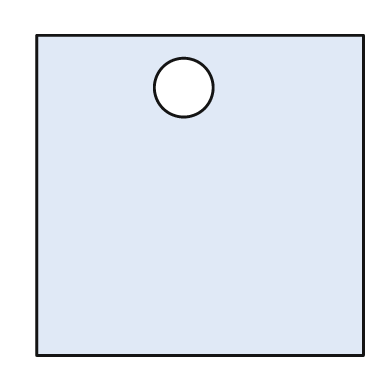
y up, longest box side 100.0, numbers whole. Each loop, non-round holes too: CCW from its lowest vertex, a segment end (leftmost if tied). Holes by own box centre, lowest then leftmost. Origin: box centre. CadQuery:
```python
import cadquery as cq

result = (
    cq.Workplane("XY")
    .moveTo(-50.0, -49.0)
    .lineTo(50.0, -49.0)
    .lineTo(50.0, 49.0)
    .lineTo(-50.0, 49.0)
    .close()
    .moveTo(-5.0, 33.0)
    .circle(9.0)
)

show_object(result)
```